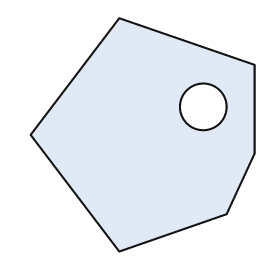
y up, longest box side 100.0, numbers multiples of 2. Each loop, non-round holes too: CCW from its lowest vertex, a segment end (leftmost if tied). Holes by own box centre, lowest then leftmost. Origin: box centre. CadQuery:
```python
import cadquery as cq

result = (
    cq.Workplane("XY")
    .moveTo(-10.0, -50.0)
    .lineTo(36.0, -34.0)
    .lineTo(48.0, -8.0)
    .lineTo(48.0, 30.0)
    .lineTo(-10.0, 50.0)
    .lineTo(-48.0, 0.0)
    .close()
    .moveTo(26.0, 12.0)
    .circle(10.0)
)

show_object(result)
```